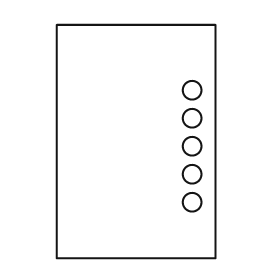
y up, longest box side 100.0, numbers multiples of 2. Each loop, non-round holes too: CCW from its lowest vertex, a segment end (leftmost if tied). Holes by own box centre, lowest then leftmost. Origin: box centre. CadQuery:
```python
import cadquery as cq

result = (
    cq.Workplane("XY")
    .moveTo(-34.0, -50.0)
    .lineTo(34.0, -50.0)
    .lineTo(34.0, 50.0)
    .lineTo(-34.0, 50.0)
    .close()
    .moveTo(24.0, -26.0)
    .circle(4.0)
    .moveTo(24.0, -14.0)
    .circle(4.0)
    .moveTo(24.0, -2.0)
    .circle(4.0)
    .moveTo(24.0, 10.0)
    .circle(4.0)
    .moveTo(24.0, 22.0)
    .circle(4.0)
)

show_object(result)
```